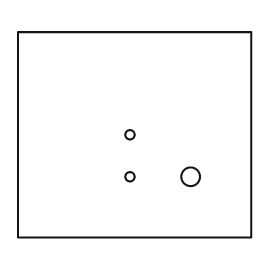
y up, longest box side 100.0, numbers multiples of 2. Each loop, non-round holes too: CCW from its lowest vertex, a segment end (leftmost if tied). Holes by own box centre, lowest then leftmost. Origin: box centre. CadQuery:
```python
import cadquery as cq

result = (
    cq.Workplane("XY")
    .moveTo(-50.0, -44.0)
    .lineTo(50.0, -44.0)
    .lineTo(50.0, 44.0)
    .lineTo(-50.0, 44.0)
    .close()
    .moveTo(-2.0, -18.0)
    .circle(2.0)
    .moveTo(24.0, -18.0)
    .circle(4.0)
    .moveTo(-2.0, 0.0)
    .circle(2.0)
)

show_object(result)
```